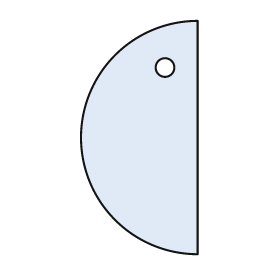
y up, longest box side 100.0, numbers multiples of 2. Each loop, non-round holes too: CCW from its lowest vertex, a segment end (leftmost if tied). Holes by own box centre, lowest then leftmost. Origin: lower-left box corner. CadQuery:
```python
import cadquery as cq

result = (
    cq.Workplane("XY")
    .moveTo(50.0, 0.0)
    .lineTo(50.0, 100.0)
    .threePointArc((0.0, 50.0), (50.0, 0.0))
    .close()
    .moveTo(36.0, 80.0)
    .circle(4.0)
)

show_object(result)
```